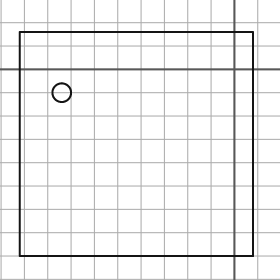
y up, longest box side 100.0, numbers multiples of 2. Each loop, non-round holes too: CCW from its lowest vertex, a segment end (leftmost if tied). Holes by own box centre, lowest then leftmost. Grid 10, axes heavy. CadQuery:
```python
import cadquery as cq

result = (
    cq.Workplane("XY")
    .moveTo(-92.0, -80.0)
    .lineTo(8.0, -80.0)
    .lineTo(8.0, 16.0)
    .lineTo(-92.0, 16.0)
    .close()
    .moveTo(-74.0, -10.0)
    .circle(4.0)
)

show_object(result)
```